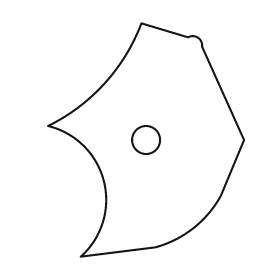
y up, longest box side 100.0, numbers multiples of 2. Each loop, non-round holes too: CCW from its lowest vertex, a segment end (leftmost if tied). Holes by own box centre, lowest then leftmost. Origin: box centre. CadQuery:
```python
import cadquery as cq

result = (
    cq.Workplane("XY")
    .moveTo(-28.0, -50.0)
    .lineTo(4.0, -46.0)
    .threePointArc((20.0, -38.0), (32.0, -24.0))
    .lineTo(42.0, 0.0)
    .lineTo(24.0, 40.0)
    .threePointArc((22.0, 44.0), (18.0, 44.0))
    .lineTo(-2.0, 50.0)
    .threePointArc((-18.0, 24.0), (-42.0, 6.0))
    .threePointArc((-18.0, -18.0), (-28.0, -50.0))
    .close()
    .moveTo(0.0, 0.0)
    .circle(6.0)
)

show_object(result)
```